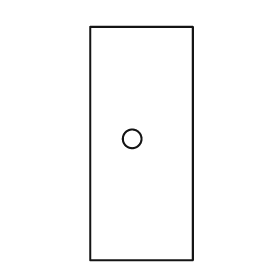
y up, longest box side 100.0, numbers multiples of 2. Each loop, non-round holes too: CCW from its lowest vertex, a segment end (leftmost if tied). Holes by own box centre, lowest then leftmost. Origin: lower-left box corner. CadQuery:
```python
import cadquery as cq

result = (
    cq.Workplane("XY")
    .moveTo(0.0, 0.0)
    .lineTo(44.0, 0.0)
    .lineTo(44.0, 100.0)
    .lineTo(0.0, 100.0)
    .close()
    .moveTo(18.0, 52.0)
    .circle(4.0)
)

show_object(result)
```